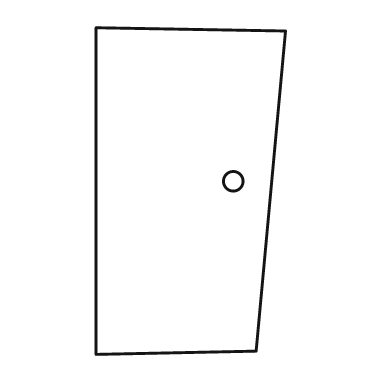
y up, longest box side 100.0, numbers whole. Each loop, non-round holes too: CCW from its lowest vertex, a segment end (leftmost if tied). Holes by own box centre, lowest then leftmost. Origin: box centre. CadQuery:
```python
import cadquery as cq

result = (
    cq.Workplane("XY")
    .moveTo(-29.0, -50.0)
    .lineTo(20.0, -49.0)
    .lineTo(29.0, 49.0)
    .lineTo(-29.0, 50.0)
    .close()
    .moveTo(13.0, 3.0)
    .circle(3.0)
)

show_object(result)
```